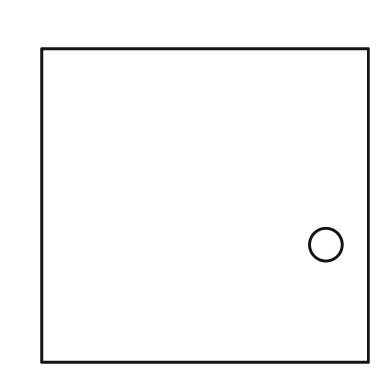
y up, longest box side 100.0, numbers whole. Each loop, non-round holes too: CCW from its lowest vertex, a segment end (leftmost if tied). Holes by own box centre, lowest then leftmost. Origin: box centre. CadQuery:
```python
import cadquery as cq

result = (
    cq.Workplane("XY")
    .moveTo(-50.0, -48.0)
    .lineTo(50.0, -48.0)
    .lineTo(50.0, 48.0)
    .lineTo(-50.0, 48.0)
    .close()
    .moveTo(37.0, -12.0)
    .circle(5.0)
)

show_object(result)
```